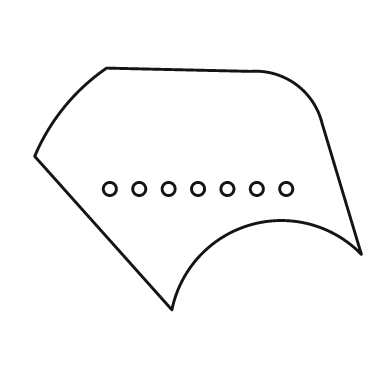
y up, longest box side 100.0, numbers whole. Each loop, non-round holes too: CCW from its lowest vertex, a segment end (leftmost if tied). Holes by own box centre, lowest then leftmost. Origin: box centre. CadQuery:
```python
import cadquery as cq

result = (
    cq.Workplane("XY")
    .moveTo(-8.0, -37.0)
    .threePointArc((16.0, -11.0), (50.0, -20.0))
    .lineTo(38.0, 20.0)
    .threePointArc((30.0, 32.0), (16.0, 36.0))
    .lineTo(-28.0, 37.0)
    .threePointArc((-41.0, 25.0), (-50.0, 10.0))
    .close()
    .moveTo(-27.0, 0.0)
    .circle(2.0)
    .moveTo(-18.0, 0.0)
    .circle(2.0)
    .moveTo(-9.0, 0.0)
    .circle(2.0)
    .moveTo(0.0, 0.0)
    .circle(2.0)
    .moveTo(9.0, 0.0)
    .circle(2.0)
    .moveTo(18.0, 0.0)
    .circle(2.0)
    .moveTo(27.0, 0.0)
    .circle(2.0)
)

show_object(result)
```